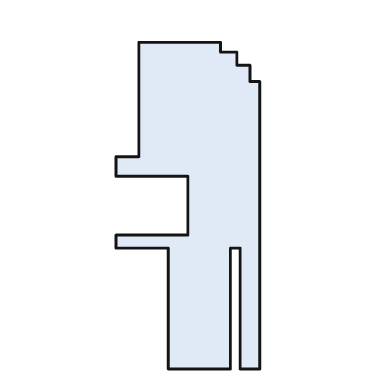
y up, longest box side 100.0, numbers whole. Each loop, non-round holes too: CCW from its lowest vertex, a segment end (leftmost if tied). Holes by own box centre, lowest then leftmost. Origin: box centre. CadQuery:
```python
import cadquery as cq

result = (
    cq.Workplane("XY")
    .moveTo(-6.0, -50.0)
    .lineTo(13.0, -50.0)
    .lineTo(13.0, -13.0)
    .lineTo(16.0, -13.0)
    .lineTo(16.0, -50.0)
    .lineTo(22.0, -50.0)
    .lineTo(22.0, 38.0)
    .lineTo(19.0, 38.0)
    .lineTo(19.0, 43.0)
    .lineTo(15.0, 43.0)
    .lineTo(15.0, 47.0)
    .lineTo(10.0, 47.0)
    .lineTo(10.0, 50.0)
    .lineTo(-15.0, 50.0)
    .lineTo(-15.0, 15.0)
    .lineTo(-22.0, 15.0)
    .lineTo(-22.0, 9.0)
    .lineTo(0.0, 9.0)
    .lineTo(0.0, -9.0)
    .lineTo(-22.0, -9.0)
    .lineTo(-22.0, -13.0)
    .lineTo(-6.0, -13.0)
    .close()
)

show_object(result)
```